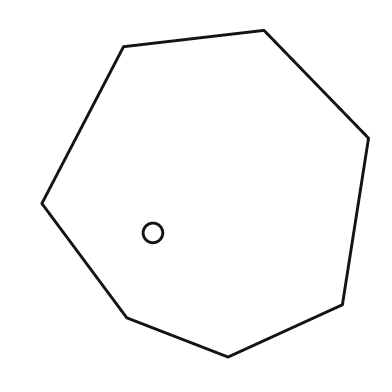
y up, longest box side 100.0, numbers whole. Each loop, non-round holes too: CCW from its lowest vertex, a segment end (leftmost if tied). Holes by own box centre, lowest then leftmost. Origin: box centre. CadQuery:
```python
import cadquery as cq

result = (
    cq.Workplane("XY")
    .moveTo(7.0, -50.0)
    .lineTo(42.0, -34.0)
    .lineTo(50.0, 17.0)
    .lineTo(18.0, 50.0)
    .lineTo(-25.0, 45.0)
    .lineTo(-50.0, -3.0)
    .lineTo(-24.0, -38.0)
    .close()
    .moveTo(-16.0, -12.0)
    .circle(3.0)
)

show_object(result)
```